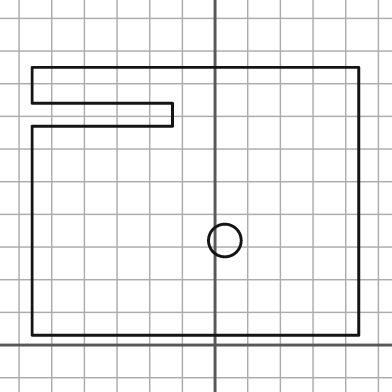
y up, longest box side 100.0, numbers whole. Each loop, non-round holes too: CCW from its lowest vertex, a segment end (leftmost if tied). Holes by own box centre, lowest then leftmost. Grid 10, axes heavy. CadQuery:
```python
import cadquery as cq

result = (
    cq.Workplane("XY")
    .moveTo(-56.0, 3.0)
    .lineTo(44.0, 3.0)
    .lineTo(44.0, 85.0)
    .lineTo(-56.0, 85.0)
    .lineTo(-56.0, 74.0)
    .lineTo(-13.0, 74.0)
    .lineTo(-13.0, 67.0)
    .lineTo(-56.0, 67.0)
    .close()
    .moveTo(3.0, 32.0)
    .circle(5.0)
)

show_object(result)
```